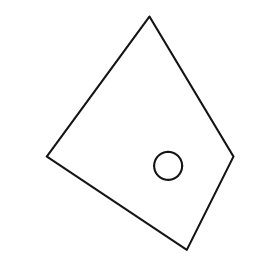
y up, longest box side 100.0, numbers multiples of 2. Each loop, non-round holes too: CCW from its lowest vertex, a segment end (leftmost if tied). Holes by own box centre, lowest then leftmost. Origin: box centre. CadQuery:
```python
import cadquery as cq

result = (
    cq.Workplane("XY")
    .moveTo(20.0, -50.0)
    .lineTo(40.0, -10.0)
    .lineTo(4.0, 50.0)
    .lineTo(-40.0, -10.0)
    .close()
    .moveTo(12.0, -14.0)
    .circle(6.0)
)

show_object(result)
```